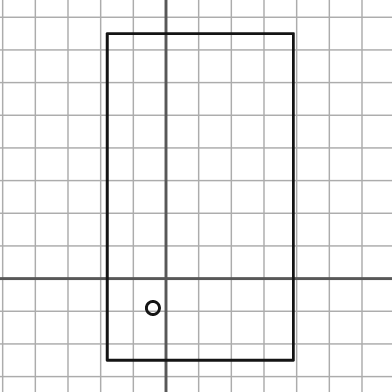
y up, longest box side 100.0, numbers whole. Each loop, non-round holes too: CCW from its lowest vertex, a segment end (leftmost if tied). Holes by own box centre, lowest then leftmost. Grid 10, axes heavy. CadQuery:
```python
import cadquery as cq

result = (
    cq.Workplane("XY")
    .moveTo(-18.0, -25.0)
    .lineTo(39.0, -25.0)
    .lineTo(39.0, 75.0)
    .lineTo(-18.0, 75.0)
    .close()
    .moveTo(-4.0, -9.0)
    .circle(2.0)
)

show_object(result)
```